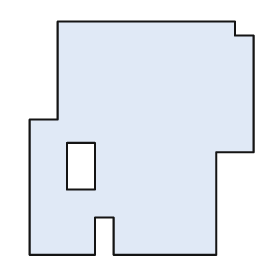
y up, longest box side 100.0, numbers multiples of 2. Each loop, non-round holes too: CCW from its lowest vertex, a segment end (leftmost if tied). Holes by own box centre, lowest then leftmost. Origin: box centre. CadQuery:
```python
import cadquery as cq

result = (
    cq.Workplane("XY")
    .moveTo(-48.0, -50.0)
    .lineTo(-20.0, -50.0)
    .lineTo(-20.0, -34.0)
    .lineTo(-12.0, -34.0)
    .lineTo(-12.0, -50.0)
    .lineTo(32.0, -50.0)
    .lineTo(32.0, -6.0)
    .lineTo(48.0, -6.0)
    .lineTo(48.0, 44.0)
    .lineTo(40.0, 44.0)
    .lineTo(40.0, 50.0)
    .lineTo(-36.0, 50.0)
    .lineTo(-36.0, 8.0)
    .lineTo(-48.0, 8.0)
    .close()
    .moveTo(-32.0, -22.0)
    .lineTo(-20.0, -22.0)
    .lineTo(-20.0, -2.0)
    .lineTo(-32.0, -2.0)
    .close()
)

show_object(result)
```